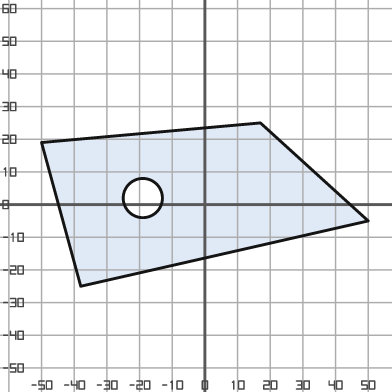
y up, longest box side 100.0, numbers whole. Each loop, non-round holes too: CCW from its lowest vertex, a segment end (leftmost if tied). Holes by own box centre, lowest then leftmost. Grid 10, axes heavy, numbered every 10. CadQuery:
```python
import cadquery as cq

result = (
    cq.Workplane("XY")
    .moveTo(-38.0, -25.0)
    .lineTo(50.0, -5.0)
    .lineTo(17.0, 25.0)
    .lineTo(-50.0, 19.0)
    .close()
    .moveTo(-19.0, 2.0)
    .circle(6.0)
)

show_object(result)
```